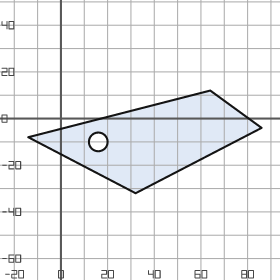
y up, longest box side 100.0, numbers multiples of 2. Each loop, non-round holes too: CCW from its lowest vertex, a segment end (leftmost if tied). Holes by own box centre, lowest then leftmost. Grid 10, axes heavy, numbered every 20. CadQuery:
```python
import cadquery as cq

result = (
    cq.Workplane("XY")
    .moveTo(32.0, -32.0)
    .lineTo(86.0, -4.0)
    .lineTo(64.0, 12.0)
    .lineTo(-14.0, -8.0)
    .close()
    .moveTo(16.0, -10.0)
    .circle(4.0)
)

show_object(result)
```